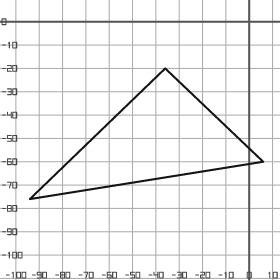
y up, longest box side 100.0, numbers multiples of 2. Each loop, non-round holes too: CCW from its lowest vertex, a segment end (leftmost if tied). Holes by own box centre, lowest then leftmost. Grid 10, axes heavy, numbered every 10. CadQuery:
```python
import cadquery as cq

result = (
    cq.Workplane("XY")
    .moveTo(-94.0, -76.0)
    .lineTo(6.0, -60.0)
    .lineTo(-36.0, -20.0)
    .close()
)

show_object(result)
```